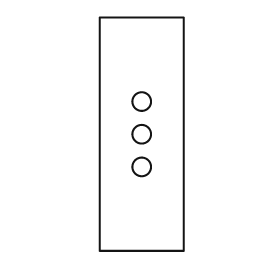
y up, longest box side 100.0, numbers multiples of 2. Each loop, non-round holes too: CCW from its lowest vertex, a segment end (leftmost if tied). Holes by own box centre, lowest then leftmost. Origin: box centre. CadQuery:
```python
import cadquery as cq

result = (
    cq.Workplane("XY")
    .moveTo(-18.0, -50.0)
    .lineTo(18.0, -50.0)
    .lineTo(18.0, 50.0)
    .lineTo(-18.0, 50.0)
    .close()
    .moveTo(0.0, -14.0)
    .circle(4.0)
    .moveTo(0.0, 0.0)
    .circle(4.0)
    .moveTo(0.0, 14.0)
    .circle(4.0)
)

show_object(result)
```